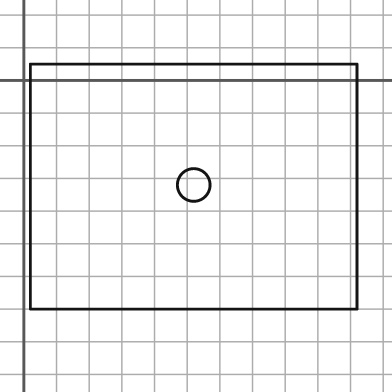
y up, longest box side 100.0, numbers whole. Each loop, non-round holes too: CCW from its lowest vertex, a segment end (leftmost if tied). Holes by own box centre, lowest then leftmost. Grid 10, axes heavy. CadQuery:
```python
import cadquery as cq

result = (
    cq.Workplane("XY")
    .moveTo(2.0, -70.0)
    .lineTo(102.0, -70.0)
    .lineTo(102.0, 5.0)
    .lineTo(2.0, 5.0)
    .close()
    .moveTo(52.0, -32.0)
    .circle(5.0)
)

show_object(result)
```